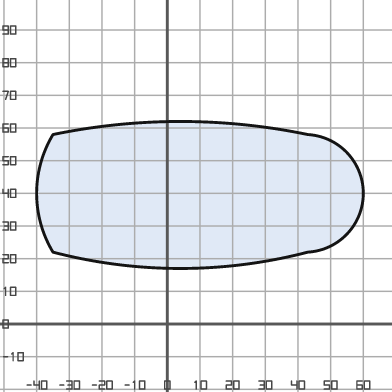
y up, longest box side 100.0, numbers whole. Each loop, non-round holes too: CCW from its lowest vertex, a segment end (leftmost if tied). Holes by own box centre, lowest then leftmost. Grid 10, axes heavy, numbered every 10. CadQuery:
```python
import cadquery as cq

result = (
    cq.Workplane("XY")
    .moveTo(-35.0, 22.0)
    .threePointArc((4.0, 17.0), (43.0, 22.0))
    .threePointArc((60.0, 40.0), (43.0, 58.0))
    .threePointArc((4.0, 62.0), (-35.0, 58.0))
    .threePointArc((-40.0, 40.0), (-35.0, 22.0))
    .close()
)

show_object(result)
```